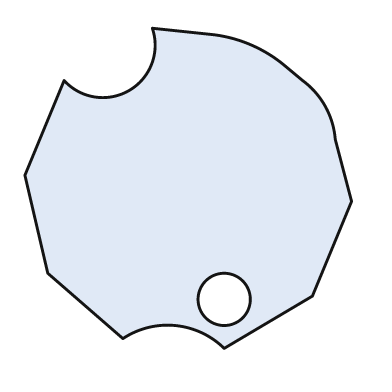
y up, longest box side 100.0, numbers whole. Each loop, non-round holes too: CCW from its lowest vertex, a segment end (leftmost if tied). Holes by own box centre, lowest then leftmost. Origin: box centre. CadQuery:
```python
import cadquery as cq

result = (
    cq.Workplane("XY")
    .moveTo(11.0, -49.0)
    .lineTo(38.0, -33.0)
    .lineTo(50.0, -4.0)
    .lineTo(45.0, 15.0)
    .threePointArc((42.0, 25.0), (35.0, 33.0))
    .lineTo(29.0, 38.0)
    .threePointArc((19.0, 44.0), (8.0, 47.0))
    .lineTo(-11.0, 49.0)
    .threePointArc((-18.0, 30.0), (-38.0, 33.0))
    .lineTo(-50.0, 4.0)
    .lineTo(-43.0, -26.0)
    .lineTo(-20.0, -46.0)
    .threePointArc((-4.0, -42.0), (11.0, -49.0))
    .close()
    .moveTo(11.0, -34.0)
    .circle(8.0)
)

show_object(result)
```